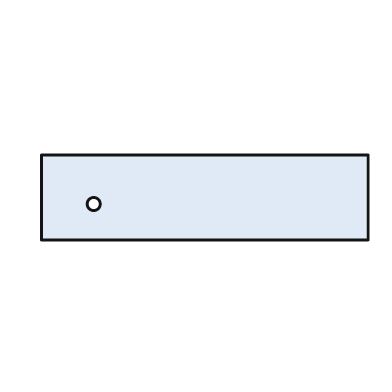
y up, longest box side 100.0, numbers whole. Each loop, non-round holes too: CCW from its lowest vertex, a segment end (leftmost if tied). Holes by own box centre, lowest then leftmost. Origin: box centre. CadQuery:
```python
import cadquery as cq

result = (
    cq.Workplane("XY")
    .moveTo(-50.0, -13.0)
    .lineTo(50.0, -13.0)
    .lineTo(50.0, 13.0)
    .lineTo(-50.0, 13.0)
    .close()
    .moveTo(-34.0, -2.0)
    .circle(2.0)
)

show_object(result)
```